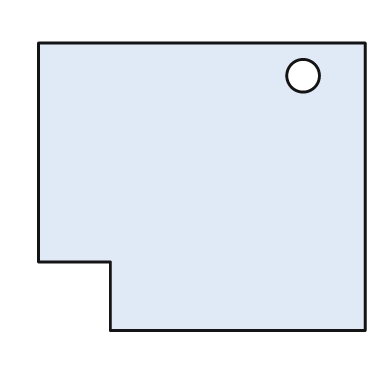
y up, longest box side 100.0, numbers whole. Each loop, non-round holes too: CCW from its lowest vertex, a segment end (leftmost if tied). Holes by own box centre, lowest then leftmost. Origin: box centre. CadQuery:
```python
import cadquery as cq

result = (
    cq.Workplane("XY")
    .moveTo(-28.0, -44.0)
    .lineTo(50.0, -44.0)
    .lineTo(50.0, 44.0)
    .lineTo(-50.0, 44.0)
    .lineTo(-50.0, -23.0)
    .lineTo(-28.0, -23.0)
    .close()
    .moveTo(31.0, 34.0)
    .circle(5.0)
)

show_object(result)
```